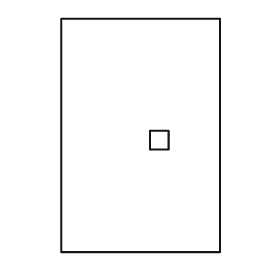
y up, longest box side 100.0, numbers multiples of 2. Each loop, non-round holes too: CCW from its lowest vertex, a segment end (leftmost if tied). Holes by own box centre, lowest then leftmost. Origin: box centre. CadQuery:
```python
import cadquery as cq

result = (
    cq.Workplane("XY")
    .moveTo(-34.0, -50.0)
    .lineTo(34.0, -50.0)
    .lineTo(34.0, 50.0)
    .lineTo(-34.0, 50.0)
    .close()
    .moveTo(4.0, -6.0)
    .lineTo(12.0, -6.0)
    .lineTo(12.0, 2.0)
    .lineTo(4.0, 2.0)
    .close()
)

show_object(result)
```